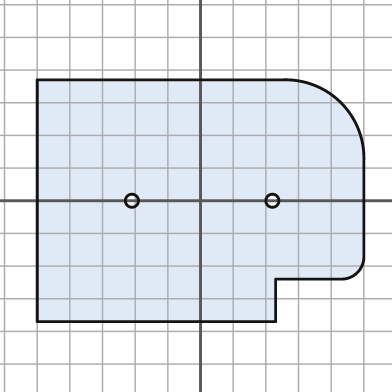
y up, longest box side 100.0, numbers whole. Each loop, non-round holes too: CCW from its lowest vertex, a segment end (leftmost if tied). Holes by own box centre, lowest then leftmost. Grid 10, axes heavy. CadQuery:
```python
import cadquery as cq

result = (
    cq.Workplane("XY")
    .moveTo(-50.0, -37.0)
    .lineTo(23.0, -37.0)
    .lineTo(23.0, -24.0)
    .lineTo(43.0, -24.0)
    .threePointArc((48.0, -22.0), (50.0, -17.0))
    .lineTo(50.0, 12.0)
    .threePointArc((43.0, 30.0), (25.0, 37.0))
    .lineTo(-50.0, 37.0)
    .close()
    .moveTo(-21.0, 0.0)
    .circle(2.0)
    .moveTo(22.0, 0.0)
    .circle(2.0)
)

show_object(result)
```